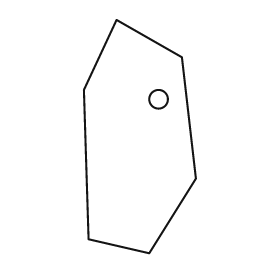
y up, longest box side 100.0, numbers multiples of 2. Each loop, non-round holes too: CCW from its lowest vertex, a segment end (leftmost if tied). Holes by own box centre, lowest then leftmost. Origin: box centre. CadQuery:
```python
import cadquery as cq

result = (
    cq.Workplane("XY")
    .moveTo(4.0, -50.0)
    .lineTo(24.0, -18.0)
    .lineTo(18.0, 34.0)
    .lineTo(-10.0, 50.0)
    .lineTo(-24.0, 20.0)
    .lineTo(-22.0, -44.0)
    .close()
    .moveTo(8.0, 16.0)
    .circle(4.0)
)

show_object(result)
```